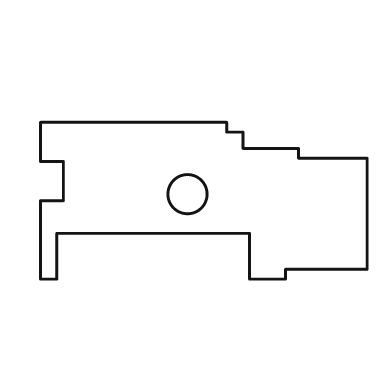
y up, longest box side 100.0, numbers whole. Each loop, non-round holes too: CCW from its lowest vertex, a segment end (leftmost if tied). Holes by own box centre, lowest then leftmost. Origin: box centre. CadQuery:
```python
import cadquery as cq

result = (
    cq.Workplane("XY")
    .moveTo(-50.0, -24.0)
    .lineTo(-45.0, -24.0)
    .lineTo(-45.0, -10.0)
    .lineTo(14.0, -10.0)
    .lineTo(14.0, -24.0)
    .lineTo(25.0, -24.0)
    .lineTo(25.0, -21.0)
    .lineTo(50.0, -21.0)
    .lineTo(50.0, 13.0)
    .lineTo(29.0, 13.0)
    .lineTo(29.0, 16.0)
    .lineTo(12.0, 16.0)
    .lineTo(12.0, 21.0)
    .lineTo(7.0, 21.0)
    .lineTo(7.0, 24.0)
    .lineTo(-50.0, 24.0)
    .lineTo(-50.0, 12.0)
    .lineTo(-43.0, 12.0)
    .lineTo(-43.0, 0.0)
    .lineTo(-50.0, 0.0)
    .close()
    .moveTo(-5.0, 2.0)
    .circle(6.0)
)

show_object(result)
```